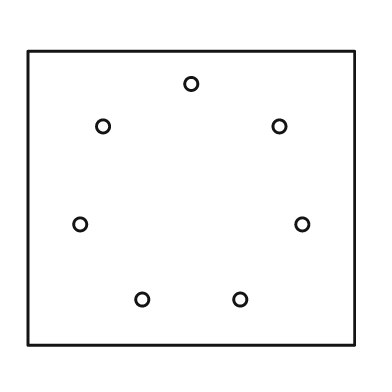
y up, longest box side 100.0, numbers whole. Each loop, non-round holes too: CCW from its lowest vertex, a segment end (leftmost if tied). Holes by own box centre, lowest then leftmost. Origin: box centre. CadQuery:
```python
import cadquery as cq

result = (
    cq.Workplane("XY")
    .moveTo(-50.0, -45.0)
    .lineTo(50.0, -45.0)
    .lineTo(50.0, 45.0)
    .lineTo(-50.0, 45.0)
    .close()
    .moveTo(-15.0, -31.0)
    .circle(2.0)
    .moveTo(15.0, -31.0)
    .circle(2.0)
    .moveTo(-34.0, -8.0)
    .circle(2.0)
    .moveTo(34.0, -8.0)
    .circle(2.0)
    .moveTo(-27.0, 22.0)
    .circle(2.0)
    .moveTo(27.0, 22.0)
    .circle(2.0)
    .moveTo(0.0, 35.0)
    .circle(2.0)
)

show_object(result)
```